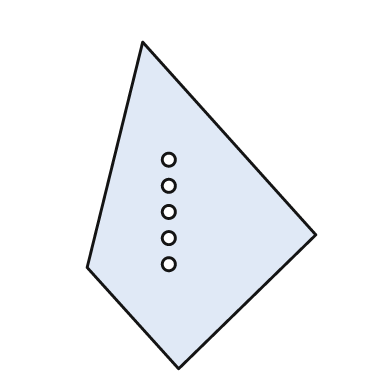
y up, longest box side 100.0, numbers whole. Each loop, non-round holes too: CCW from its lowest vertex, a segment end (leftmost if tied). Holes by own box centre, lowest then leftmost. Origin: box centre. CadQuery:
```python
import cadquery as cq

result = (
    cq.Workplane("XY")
    .moveTo(-7.0, -50.0)
    .lineTo(35.0, -9.0)
    .lineTo(-18.0, 50.0)
    .lineTo(-35.0, -19.0)
    .close()
    .moveTo(-10.0, -18.0)
    .circle(2.0)
    .moveTo(-10.0, -10.0)
    .circle(2.0)
    .moveTo(-10.0, -2.0)
    .circle(2.0)
    .moveTo(-10.0, 6.0)
    .circle(2.0)
    .moveTo(-10.0, 14.0)
    .circle(2.0)
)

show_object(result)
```